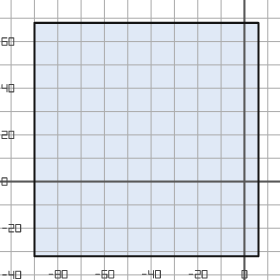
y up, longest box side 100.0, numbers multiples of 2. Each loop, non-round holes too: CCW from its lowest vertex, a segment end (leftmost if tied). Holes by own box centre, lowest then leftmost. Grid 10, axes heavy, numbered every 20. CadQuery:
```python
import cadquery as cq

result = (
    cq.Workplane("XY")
    .moveTo(-90.0, -32.0)
    .lineTo(6.0, -32.0)
    .lineTo(6.0, 68.0)
    .lineTo(-90.0, 68.0)
    .close()
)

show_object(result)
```